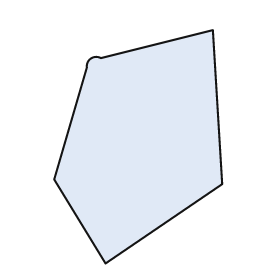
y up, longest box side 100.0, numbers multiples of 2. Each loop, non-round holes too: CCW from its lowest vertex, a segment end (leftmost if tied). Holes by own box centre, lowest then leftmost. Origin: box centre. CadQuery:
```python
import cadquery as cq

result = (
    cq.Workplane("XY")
    .moveTo(-14.0, -50.0)
    .lineTo(36.0, -16.0)
    .lineTo(32.0, 50.0)
    .lineTo(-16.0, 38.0)
    .threePointArc((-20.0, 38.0), (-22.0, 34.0))
    .lineTo(-36.0, -14.0)
    .close()
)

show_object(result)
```